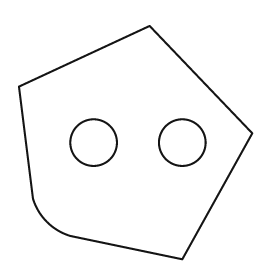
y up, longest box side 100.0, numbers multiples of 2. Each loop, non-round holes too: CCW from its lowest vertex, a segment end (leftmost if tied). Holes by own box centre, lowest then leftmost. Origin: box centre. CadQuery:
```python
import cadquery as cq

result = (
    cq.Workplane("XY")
    .moveTo(20.0, -50.0)
    .lineTo(50.0, 4.0)
    .lineTo(6.0, 50.0)
    .lineTo(-50.0, 24.0)
    .lineTo(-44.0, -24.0)
    .threePointArc((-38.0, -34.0), (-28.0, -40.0))
    .close()
    .moveTo(-18.0, 0.0)
    .circle(10.0)
    .moveTo(20.0, 0.0)
    .circle(10.0)
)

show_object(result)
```